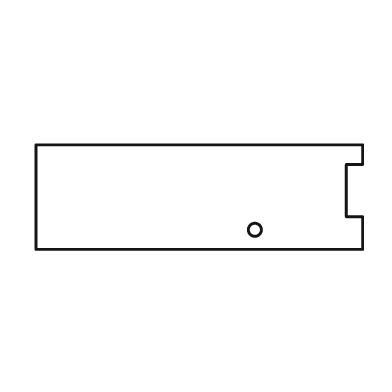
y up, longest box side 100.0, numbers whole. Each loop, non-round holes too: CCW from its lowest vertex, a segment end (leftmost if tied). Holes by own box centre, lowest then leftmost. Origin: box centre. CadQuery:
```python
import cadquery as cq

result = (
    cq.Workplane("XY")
    .moveTo(-50.0, -16.0)
    .lineTo(50.0, -16.0)
    .lineTo(50.0, -6.0)
    .lineTo(45.0, -6.0)
    .lineTo(45.0, 10.0)
    .lineTo(50.0, 10.0)
    .lineTo(50.0, 16.0)
    .lineTo(-50.0, 16.0)
    .close()
    .moveTo(17.0, -10.0)
    .circle(2.0)
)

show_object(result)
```